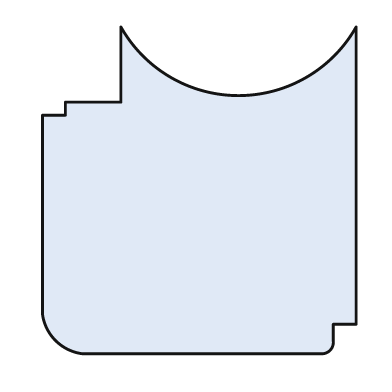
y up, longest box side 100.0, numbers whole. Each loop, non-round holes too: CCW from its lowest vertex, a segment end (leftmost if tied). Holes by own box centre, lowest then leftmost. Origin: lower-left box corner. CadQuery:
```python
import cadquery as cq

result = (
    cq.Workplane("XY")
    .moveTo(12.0, 0.0)
    .lineTo(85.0, 0.0)
    .threePointArc((88.0, 1.0), (89.0, 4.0))
    .lineTo(89.0, 9.0)
    .lineTo(96.0, 9.0)
    .lineTo(96.0, 100.0)
    .threePointArc((60.0, 79.0), (24.0, 100.0))
    .lineTo(24.0, 77.0)
    .lineTo(7.0, 77.0)
    .lineTo(7.0, 73.0)
    .lineTo(0.0, 73.0)
    .lineTo(0.0, 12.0)
    .threePointArc((4.0, 4.0), (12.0, 0.0))
    .close()
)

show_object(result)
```